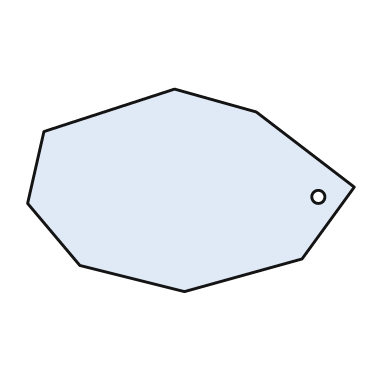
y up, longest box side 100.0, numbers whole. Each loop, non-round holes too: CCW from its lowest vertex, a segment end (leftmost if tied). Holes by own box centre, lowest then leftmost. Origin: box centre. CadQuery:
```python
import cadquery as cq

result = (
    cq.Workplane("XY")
    .moveTo(-2.0, -31.0)
    .lineTo(34.0, -21.0)
    .lineTo(50.0, 1.0)
    .lineTo(20.0, 24.0)
    .lineTo(-5.0, 31.0)
    .lineTo(-45.0, 18.0)
    .lineTo(-50.0, -4.0)
    .lineTo(-34.0, -23.0)
    .close()
    .moveTo(39.0, -2.0)
    .circle(2.0)
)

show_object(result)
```